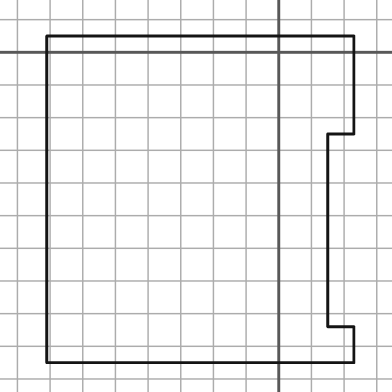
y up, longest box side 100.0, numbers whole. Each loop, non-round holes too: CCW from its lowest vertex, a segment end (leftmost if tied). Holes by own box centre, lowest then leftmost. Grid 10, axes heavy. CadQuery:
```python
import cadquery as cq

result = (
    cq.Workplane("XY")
    .moveTo(-71.0, -95.0)
    .lineTo(23.0, -95.0)
    .lineTo(23.0, -84.0)
    .lineTo(15.0, -84.0)
    .lineTo(15.0, -25.0)
    .lineTo(23.0, -25.0)
    .lineTo(23.0, 5.0)
    .lineTo(-71.0, 5.0)
    .close()
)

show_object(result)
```